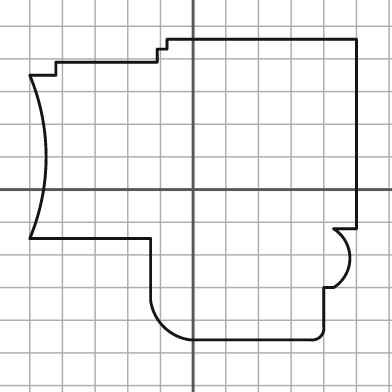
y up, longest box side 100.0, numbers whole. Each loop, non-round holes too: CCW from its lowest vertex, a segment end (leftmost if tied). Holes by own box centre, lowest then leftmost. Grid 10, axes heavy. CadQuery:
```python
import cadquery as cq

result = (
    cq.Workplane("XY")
    .moveTo(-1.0, -46.0)
    .lineTo(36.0, -46.0)
    .threePointArc((39.0, -45.0), (40.0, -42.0))
    .lineTo(40.0, -30.0)
    .lineTo(43.0, -30.0)
    .threePointArc((48.0, -21.0), (43.0, -12.0))
    .lineTo(50.0, -12.0)
    .lineTo(50.0, 46.0)
    .lineTo(-8.0, 46.0)
    .lineTo(-8.0, 43.0)
    .lineTo(-11.0, 43.0)
    .lineTo(-11.0, 39.0)
    .lineTo(-42.0, 39.0)
    .lineTo(-42.0, 35.0)
    .lineTo(-50.0, 35.0)
    .threePointArc((-45.0, 10.0), (-50.0, -15.0))
    .lineTo(-13.0, -15.0)
    .lineTo(-13.0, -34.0)
    .threePointArc((-9.0, -42.0), (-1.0, -46.0))
    .close()
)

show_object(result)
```